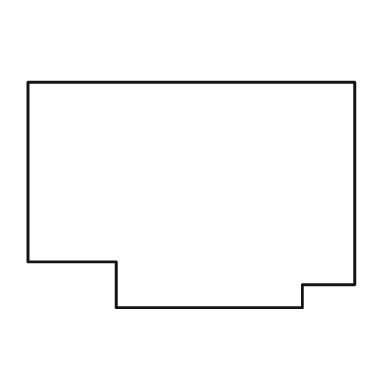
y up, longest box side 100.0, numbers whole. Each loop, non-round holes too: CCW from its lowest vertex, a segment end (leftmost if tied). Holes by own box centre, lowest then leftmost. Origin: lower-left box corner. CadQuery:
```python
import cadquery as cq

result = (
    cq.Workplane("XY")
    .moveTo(27.0, 0.0)
    .lineTo(84.0, 0.0)
    .lineTo(84.0, 7.0)
    .lineTo(100.0, 7.0)
    .lineTo(100.0, 69.0)
    .lineTo(0.0, 69.0)
    .lineTo(0.0, 14.0)
    .lineTo(27.0, 14.0)
    .close()
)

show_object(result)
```